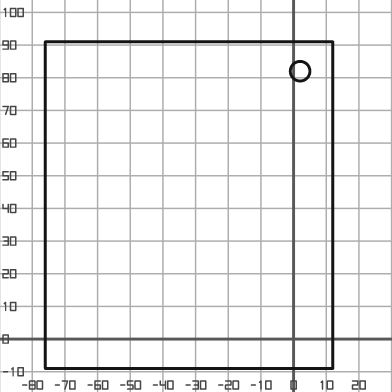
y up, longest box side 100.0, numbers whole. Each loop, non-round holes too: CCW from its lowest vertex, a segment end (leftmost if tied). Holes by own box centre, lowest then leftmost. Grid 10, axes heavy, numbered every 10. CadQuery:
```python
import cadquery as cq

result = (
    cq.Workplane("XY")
    .moveTo(-76.0, -9.0)
    .lineTo(12.0, -9.0)
    .lineTo(12.0, 91.0)
    .lineTo(-76.0, 91.0)
    .close()
    .moveTo(2.0, 82.0)
    .circle(3.0)
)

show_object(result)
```